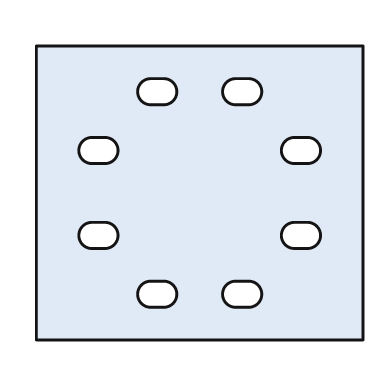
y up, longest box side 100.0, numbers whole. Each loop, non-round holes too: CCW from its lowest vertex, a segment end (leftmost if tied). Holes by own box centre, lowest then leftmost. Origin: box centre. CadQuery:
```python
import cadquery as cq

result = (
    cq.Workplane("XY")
    .moveTo(-50.0, -45.0)
    .lineTo(50.0, -45.0)
    .lineTo(50.0, 45.0)
    .lineTo(-50.0, 45.0)
    .close()
    .moveTo(-15.0, -35.0)
    .lineTo(-11.0, -35.0)
    .threePointArc((-7.0, -31.0), (-11.0, -27.0))
    .lineTo(-15.0, -27.0)
    .threePointArc((-19.0, -31.0), (-15.0, -35.0))
    .close()
    .moveTo(11.0, -35.0)
    .lineTo(15.0, -35.0)
    .threePointArc((19.0, -31.0), (15.0, -27.0))
    .lineTo(11.0, -27.0)
    .threePointArc((7.0, -31.0), (11.0, -35.0))
    .close()
    .moveTo(-33.0, -17.0)
    .lineTo(-29.0, -17.0)
    .threePointArc((-25.0, -13.0), (-29.0, -9.0))
    .lineTo(-33.0, -9.0)
    .threePointArc((-37.0, -13.0), (-33.0, -17.0))
    .close()
    .moveTo(29.0, -17.0)
    .lineTo(33.0, -17.0)
    .threePointArc((37.0, -13.0), (33.0, -9.0))
    .lineTo(29.0, -9.0)
    .threePointArc((25.0, -13.0), (29.0, -17.0))
    .close()
    .moveTo(-33.0, 9.0)
    .lineTo(-29.0, 9.0)
    .threePointArc((-25.0, 13.0), (-29.0, 17.0))
    .lineTo(-33.0, 17.0)
    .threePointArc((-37.0, 13.0), (-33.0, 9.0))
    .close()
    .moveTo(29.0, 9.0)
    .lineTo(33.0, 9.0)
    .threePointArc((37.0, 13.0), (33.0, 17.0))
    .lineTo(29.0, 17.0)
    .threePointArc((25.0, 13.0), (29.0, 9.0))
    .close()
    .moveTo(-15.0, 27.0)
    .lineTo(-11.0, 27.0)
    .threePointArc((-7.0, 31.0), (-11.0, 35.0))
    .lineTo(-15.0, 35.0)
    .threePointArc((-19.0, 31.0), (-15.0, 27.0))
    .close()
    .moveTo(11.0, 27.0)
    .lineTo(15.0, 27.0)
    .threePointArc((19.0, 31.0), (15.0, 35.0))
    .lineTo(11.0, 35.0)
    .threePointArc((7.0, 31.0), (11.0, 27.0))
    .close()
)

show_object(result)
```